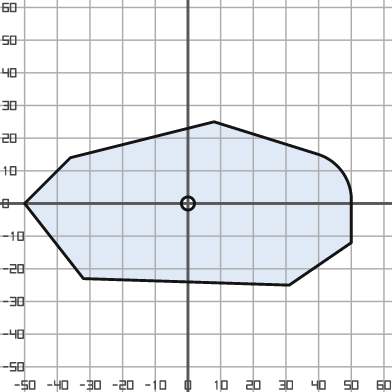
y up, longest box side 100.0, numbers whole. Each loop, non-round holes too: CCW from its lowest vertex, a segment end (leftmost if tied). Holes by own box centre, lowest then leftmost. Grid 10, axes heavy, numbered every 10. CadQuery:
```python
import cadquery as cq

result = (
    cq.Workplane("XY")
    .moveTo(31.0, -25.0)
    .lineTo(50.0, -12.0)
    .lineTo(50.0, 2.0)
    .threePointArc((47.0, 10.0), (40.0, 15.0))
    .lineTo(8.0, 25.0)
    .lineTo(-36.0, 14.0)
    .lineTo(-50.0, 0.0)
    .lineTo(-32.0, -23.0)
    .close()
    .moveTo(0.0, 0.0)
    .circle(2.0)
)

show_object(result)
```